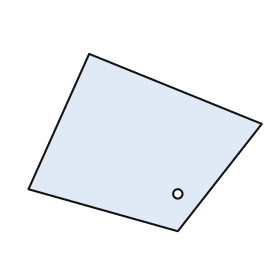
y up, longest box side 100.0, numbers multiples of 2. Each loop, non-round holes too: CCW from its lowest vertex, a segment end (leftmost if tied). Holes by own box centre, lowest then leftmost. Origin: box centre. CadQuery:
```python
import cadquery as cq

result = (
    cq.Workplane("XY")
    .moveTo(14.0, -38.0)
    .lineTo(50.0, 8.0)
    .lineTo(-24.0, 38.0)
    .lineTo(-50.0, -20.0)
    .close()
    .moveTo(14.0, -22.0)
    .circle(2.0)
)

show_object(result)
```